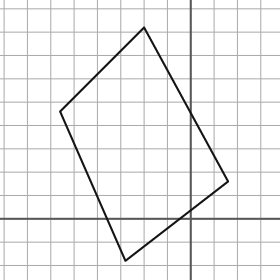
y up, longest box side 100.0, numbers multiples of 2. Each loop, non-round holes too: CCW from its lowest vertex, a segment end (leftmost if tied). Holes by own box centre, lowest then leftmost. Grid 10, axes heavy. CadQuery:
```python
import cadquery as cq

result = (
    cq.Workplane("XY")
    .moveTo(-28.0, -18.0)
    .lineTo(16.0, 16.0)
    .lineTo(-20.0, 82.0)
    .lineTo(-56.0, 46.0)
    .close()
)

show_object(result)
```